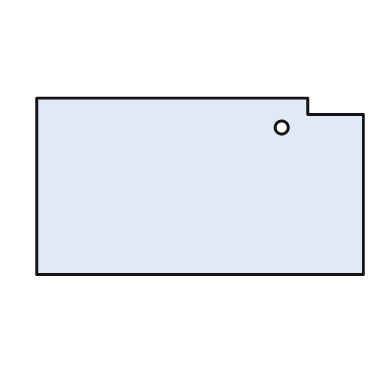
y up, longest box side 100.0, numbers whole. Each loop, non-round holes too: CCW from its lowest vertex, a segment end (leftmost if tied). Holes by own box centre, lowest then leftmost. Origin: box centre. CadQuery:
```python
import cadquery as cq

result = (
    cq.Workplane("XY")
    .moveTo(-50.0, -27.0)
    .lineTo(50.0, -27.0)
    .lineTo(50.0, 22.0)
    .lineTo(33.0, 22.0)
    .lineTo(33.0, 27.0)
    .lineTo(-50.0, 27.0)
    .close()
    .moveTo(25.0, 18.0)
    .circle(2.0)
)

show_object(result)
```